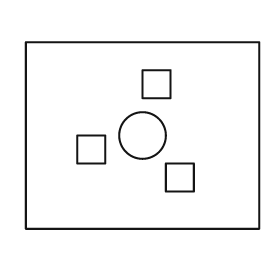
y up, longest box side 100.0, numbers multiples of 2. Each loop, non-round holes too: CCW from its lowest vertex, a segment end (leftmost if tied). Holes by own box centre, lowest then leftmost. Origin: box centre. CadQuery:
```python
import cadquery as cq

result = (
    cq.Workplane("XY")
    .moveTo(-50.0, -40.0)
    .lineTo(50.0, -40.0)
    .lineTo(50.0, 40.0)
    .lineTo(-50.0, 40.0)
    .close()
    .moveTo(10.0, -24.0)
    .lineTo(22.0, -24.0)
    .lineTo(22.0, -12.0)
    .lineTo(10.0, -12.0)
    .close()
    .moveTo(-28.0, -12.0)
    .lineTo(-16.0, -12.0)
    .lineTo(-16.0, 0.0)
    .lineTo(-28.0, 0.0)
    .close()
    .moveTo(0.0, 0.0)
    .circle(10.0)
    .moveTo(0.0, 16.0)
    .lineTo(12.0, 16.0)
    .lineTo(12.0, 28.0)
    .lineTo(0.0, 28.0)
    .close()
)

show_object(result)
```